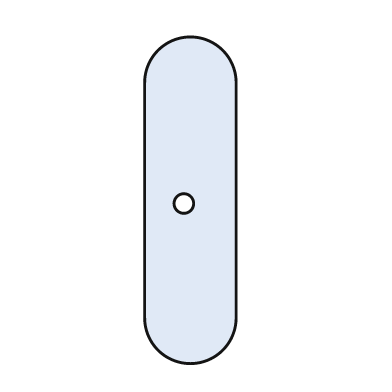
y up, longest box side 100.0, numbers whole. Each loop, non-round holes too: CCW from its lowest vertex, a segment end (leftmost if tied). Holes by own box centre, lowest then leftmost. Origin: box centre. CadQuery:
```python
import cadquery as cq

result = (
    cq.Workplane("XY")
    .moveTo(-14.0, -36.0)
    .threePointArc((0.0, -50.0), (14.0, -36.0))
    .lineTo(14.0, 36.0)
    .threePointArc((0.0, 50.0), (-14.0, 36.0))
    .close()
    .moveTo(-2.0, -1.0)
    .circle(3.0)
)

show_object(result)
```